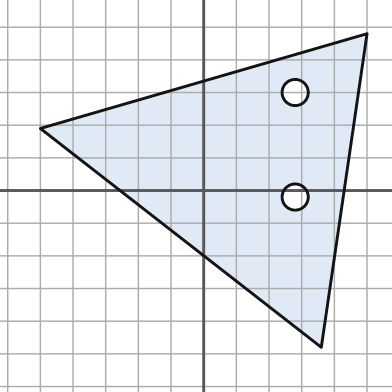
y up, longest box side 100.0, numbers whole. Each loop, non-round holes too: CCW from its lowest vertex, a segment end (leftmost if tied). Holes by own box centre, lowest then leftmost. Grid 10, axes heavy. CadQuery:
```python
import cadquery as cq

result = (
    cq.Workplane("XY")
    .moveTo(36.0, -48.0)
    .lineTo(50.0, 48.0)
    .lineTo(-50.0, 19.0)
    .close()
    .moveTo(28.0, -2.0)
    .circle(4.0)
    .moveTo(28.0, 30.0)
    .circle(4.0)
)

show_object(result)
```